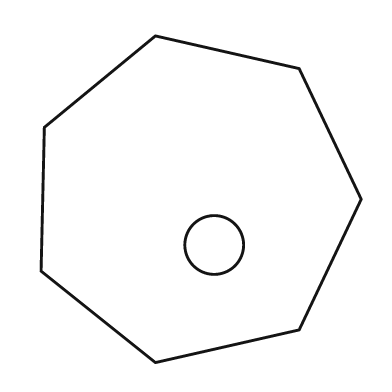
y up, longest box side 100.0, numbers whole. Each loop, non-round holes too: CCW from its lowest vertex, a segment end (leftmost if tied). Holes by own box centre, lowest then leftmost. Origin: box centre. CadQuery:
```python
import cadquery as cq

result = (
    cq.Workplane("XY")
    .moveTo(-14.0, -50.0)
    .lineTo(30.0, -40.0)
    .lineTo(49.0, 0.0)
    .lineTo(30.0, 40.0)
    .lineTo(-14.0, 50.0)
    .lineTo(-48.0, 22.0)
    .lineTo(-49.0, -22.0)
    .close()
    .moveTo(4.0, -14.0)
    .circle(9.0)
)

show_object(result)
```